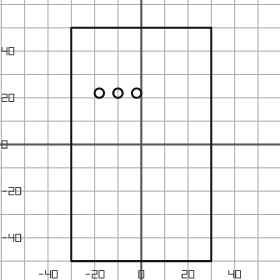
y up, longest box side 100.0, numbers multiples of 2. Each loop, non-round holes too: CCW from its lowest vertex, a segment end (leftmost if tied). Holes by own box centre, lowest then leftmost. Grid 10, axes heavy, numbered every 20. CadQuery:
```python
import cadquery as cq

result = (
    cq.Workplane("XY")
    .moveTo(-30.0, -50.0)
    .lineTo(30.0, -50.0)
    .lineTo(30.0, 50.0)
    .lineTo(-30.0, 50.0)
    .close()
    .moveTo(-18.0, 22.0)
    .circle(2.0)
    .moveTo(-10.0, 22.0)
    .circle(2.0)
    .moveTo(-2.0, 22.0)
    .circle(2.0)
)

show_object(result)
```